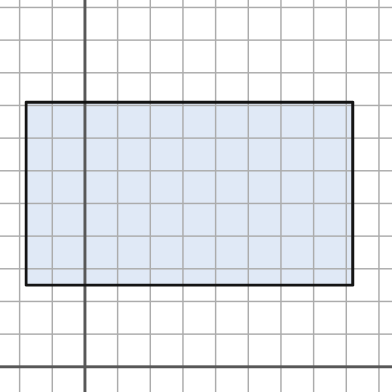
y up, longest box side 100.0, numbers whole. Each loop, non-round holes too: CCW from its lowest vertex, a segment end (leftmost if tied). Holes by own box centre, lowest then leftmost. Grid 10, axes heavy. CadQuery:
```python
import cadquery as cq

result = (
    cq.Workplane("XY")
    .moveTo(-18.0, 25.0)
    .lineTo(82.0, 25.0)
    .lineTo(82.0, 81.0)
    .lineTo(-18.0, 81.0)
    .close()
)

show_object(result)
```